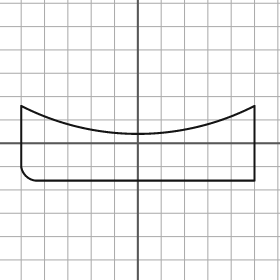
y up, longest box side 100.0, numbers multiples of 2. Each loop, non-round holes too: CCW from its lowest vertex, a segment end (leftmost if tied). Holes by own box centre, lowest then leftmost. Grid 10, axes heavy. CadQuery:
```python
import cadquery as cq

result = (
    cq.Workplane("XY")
    .moveTo(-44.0, -16.0)
    .lineTo(50.0, -16.0)
    .lineTo(50.0, 16.0)
    .threePointArc((0.0, 4.0), (-50.0, 16.0))
    .lineTo(-50.0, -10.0)
    .threePointArc((-48.0, -14.0), (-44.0, -16.0))
    .close()
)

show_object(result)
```